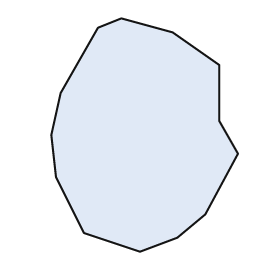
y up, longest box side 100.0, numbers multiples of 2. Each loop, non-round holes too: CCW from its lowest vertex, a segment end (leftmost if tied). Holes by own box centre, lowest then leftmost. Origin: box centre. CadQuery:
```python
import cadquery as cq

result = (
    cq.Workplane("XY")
    .moveTo(-2.0, -50.0)
    .lineTo(14.0, -44.0)
    .lineTo(26.0, -34.0)
    .lineTo(40.0, -8.0)
    .lineTo(32.0, 6.0)
    .lineTo(32.0, 30.0)
    .lineTo(12.0, 44.0)
    .lineTo(-10.0, 50.0)
    .lineTo(-20.0, 46.0)
    .lineTo(-36.0, 18.0)
    .lineTo(-40.0, 0.0)
    .lineTo(-38.0, -18.0)
    .lineTo(-26.0, -42.0)
    .close()
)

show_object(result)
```